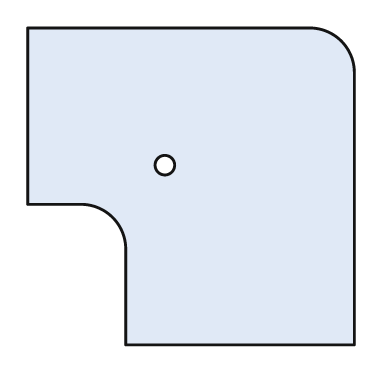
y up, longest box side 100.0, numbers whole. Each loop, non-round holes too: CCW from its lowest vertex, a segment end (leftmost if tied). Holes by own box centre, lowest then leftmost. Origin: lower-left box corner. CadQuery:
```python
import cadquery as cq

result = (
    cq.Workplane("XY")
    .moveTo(30.0, 0.0)
    .lineTo(100.0, 0.0)
    .lineTo(100.0, 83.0)
    .threePointArc((96.0, 93.0), (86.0, 97.0))
    .lineTo(0.0, 97.0)
    .lineTo(0.0, 43.0)
    .lineTo(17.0, 43.0)
    .threePointArc((26.0, 39.0), (30.0, 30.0))
    .close()
    .moveTo(42.0, 55.0)
    .circle(3.0)
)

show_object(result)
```